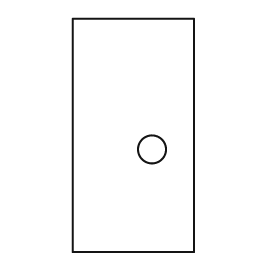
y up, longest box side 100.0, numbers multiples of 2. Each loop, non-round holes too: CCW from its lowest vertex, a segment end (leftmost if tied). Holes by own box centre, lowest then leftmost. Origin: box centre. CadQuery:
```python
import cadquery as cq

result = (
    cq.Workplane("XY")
    .moveTo(-26.0, -50.0)
    .lineTo(26.0, -50.0)
    .lineTo(26.0, 50.0)
    .lineTo(-26.0, 50.0)
    .close()
    .moveTo(8.0, -6.0)
    .circle(6.0)
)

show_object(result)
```